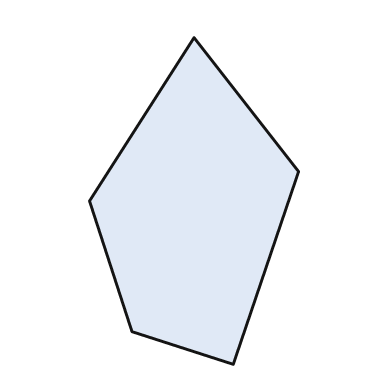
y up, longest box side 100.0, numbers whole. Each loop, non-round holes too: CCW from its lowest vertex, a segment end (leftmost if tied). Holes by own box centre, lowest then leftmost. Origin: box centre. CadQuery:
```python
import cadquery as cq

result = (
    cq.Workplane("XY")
    .moveTo(12.0, -50.0)
    .lineTo(32.0, 9.0)
    .lineTo(0.0, 50.0)
    .lineTo(-32.0, 0.0)
    .lineTo(-19.0, -40.0)
    .close()
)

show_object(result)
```